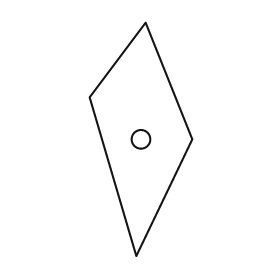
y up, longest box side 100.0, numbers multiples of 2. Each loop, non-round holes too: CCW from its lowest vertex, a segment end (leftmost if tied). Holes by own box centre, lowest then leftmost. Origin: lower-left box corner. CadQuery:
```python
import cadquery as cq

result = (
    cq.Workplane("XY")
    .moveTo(20.0, 0.0)
    .lineTo(44.0, 50.0)
    .lineTo(24.0, 100.0)
    .lineTo(0.0, 68.0)
    .close()
    .moveTo(22.0, 50.0)
    .circle(4.0)
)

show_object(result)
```